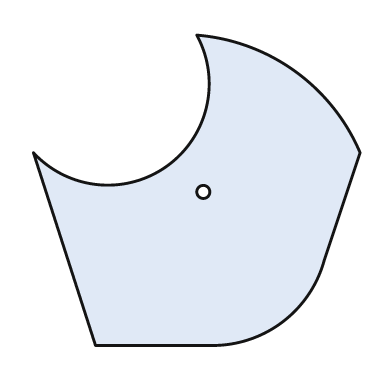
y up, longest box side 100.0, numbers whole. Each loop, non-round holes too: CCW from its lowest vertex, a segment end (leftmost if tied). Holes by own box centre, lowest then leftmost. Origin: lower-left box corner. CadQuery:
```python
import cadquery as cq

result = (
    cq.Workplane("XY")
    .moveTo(19.0, 0.0)
    .lineTo(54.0, 0.0)
    .threePointArc((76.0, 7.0), (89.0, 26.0))
    .lineTo(100.0, 59.0)
    .threePointArc((80.0, 84.0), (50.0, 95.0))
    .threePointArc((41.0, 55.0), (0.0, 59.0))
    .close()
    .moveTo(52.0, 47.0)
    .circle(2.0)
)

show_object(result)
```